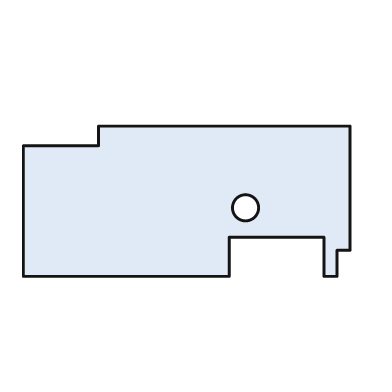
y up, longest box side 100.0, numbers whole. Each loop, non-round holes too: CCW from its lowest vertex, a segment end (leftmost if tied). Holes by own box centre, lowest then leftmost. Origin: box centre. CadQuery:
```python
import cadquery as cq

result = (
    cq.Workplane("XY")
    .moveTo(-50.0, -23.0)
    .lineTo(13.0, -23.0)
    .lineTo(13.0, -11.0)
    .lineTo(42.0, -11.0)
    .lineTo(42.0, -23.0)
    .lineTo(46.0, -23.0)
    .lineTo(46.0, -15.0)
    .lineTo(50.0, -15.0)
    .lineTo(50.0, 23.0)
    .lineTo(-27.0, 23.0)
    .lineTo(-27.0, 17.0)
    .lineTo(-50.0, 17.0)
    .close()
    .moveTo(18.0, -2.0)
    .circle(4.0)
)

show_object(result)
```